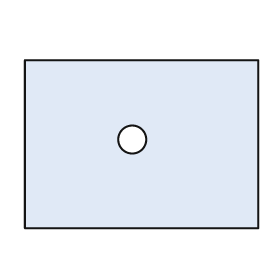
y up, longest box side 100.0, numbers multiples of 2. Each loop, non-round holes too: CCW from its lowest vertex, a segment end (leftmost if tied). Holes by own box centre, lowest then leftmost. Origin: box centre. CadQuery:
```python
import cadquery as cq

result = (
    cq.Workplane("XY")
    .moveTo(-50.0, -36.0)
    .lineTo(50.0, -36.0)
    .lineTo(50.0, 36.0)
    .lineTo(-50.0, 36.0)
    .close()
    .moveTo(-4.0, 2.0)
    .circle(6.0)
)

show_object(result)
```